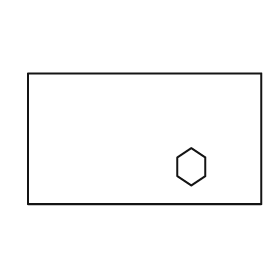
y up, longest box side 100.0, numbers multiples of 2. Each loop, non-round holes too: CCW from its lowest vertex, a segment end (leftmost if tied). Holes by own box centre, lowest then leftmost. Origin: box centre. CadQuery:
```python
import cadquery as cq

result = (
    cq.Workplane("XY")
    .moveTo(-50.0, -28.0)
    .lineTo(50.0, -28.0)
    .lineTo(50.0, 28.0)
    .lineTo(-50.0, 28.0)
    .close()
    .moveTo(20.0, -20.0)
    .lineTo(26.0, -16.0)
    .lineTo(26.0, -8.0)
    .lineTo(20.0, -4.0)
    .lineTo(14.0, -8.0)
    .lineTo(14.0, -16.0)
    .close()
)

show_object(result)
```